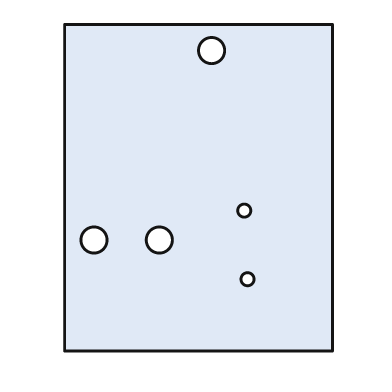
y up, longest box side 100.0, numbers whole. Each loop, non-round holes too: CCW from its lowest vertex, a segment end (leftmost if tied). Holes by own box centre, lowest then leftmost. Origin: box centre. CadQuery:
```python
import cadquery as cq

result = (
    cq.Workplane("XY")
    .moveTo(-41.0, -50.0)
    .lineTo(41.0, -50.0)
    .lineTo(41.0, 50.0)
    .lineTo(-41.0, 50.0)
    .close()
    .moveTo(15.0, -28.0)
    .circle(2.0)
    .moveTo(-32.0, -16.0)
    .circle(4.0)
    .moveTo(-12.0, -16.0)
    .circle(4.0)
    .moveTo(14.0, -7.0)
    .circle(2.0)
    .moveTo(4.0, 42.0)
    .circle(4.0)
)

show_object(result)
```